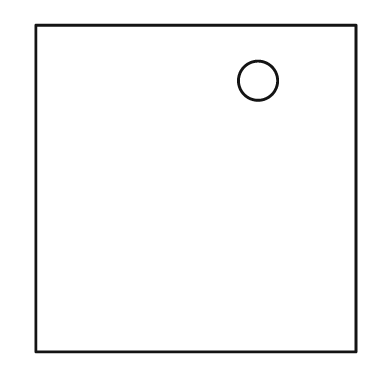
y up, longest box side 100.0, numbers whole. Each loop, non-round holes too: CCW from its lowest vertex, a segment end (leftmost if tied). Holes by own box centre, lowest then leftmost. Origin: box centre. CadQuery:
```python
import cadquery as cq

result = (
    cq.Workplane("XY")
    .moveTo(-49.0, -50.0)
    .lineTo(49.0, -50.0)
    .lineTo(49.0, 50.0)
    .lineTo(-49.0, 50.0)
    .close()
    .moveTo(19.0, 33.0)
    .circle(6.0)
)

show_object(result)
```